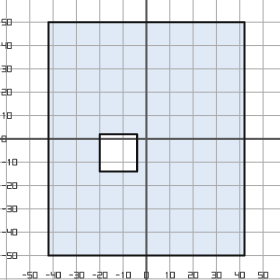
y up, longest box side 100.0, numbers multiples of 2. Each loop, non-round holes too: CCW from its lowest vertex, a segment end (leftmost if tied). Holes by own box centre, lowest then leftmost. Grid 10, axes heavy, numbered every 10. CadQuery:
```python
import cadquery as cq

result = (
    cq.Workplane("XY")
    .moveTo(-42.0, -50.0)
    .lineTo(42.0, -50.0)
    .lineTo(42.0, 50.0)
    .lineTo(-42.0, 50.0)
    .close()
    .moveTo(-20.0, -14.0)
    .lineTo(-4.0, -14.0)
    .lineTo(-4.0, 2.0)
    .lineTo(-20.0, 2.0)
    .close()
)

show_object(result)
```